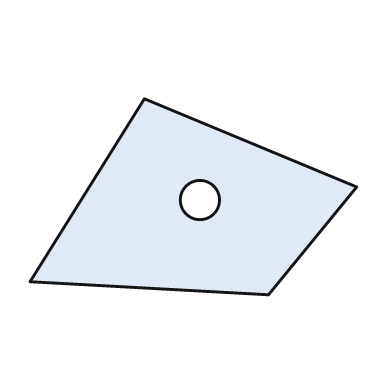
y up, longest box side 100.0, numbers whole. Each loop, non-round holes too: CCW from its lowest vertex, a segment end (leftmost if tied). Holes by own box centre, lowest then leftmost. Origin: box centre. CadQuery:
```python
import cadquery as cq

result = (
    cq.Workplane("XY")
    .moveTo(23.0, -30.0)
    .lineTo(50.0, 3.0)
    .lineTo(-15.0, 30.0)
    .lineTo(-50.0, -26.0)
    .close()
    .moveTo(2.0, -1.0)
    .circle(6.0)
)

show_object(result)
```